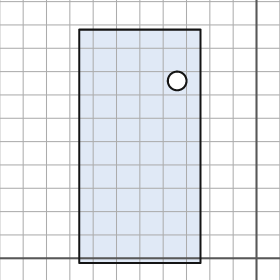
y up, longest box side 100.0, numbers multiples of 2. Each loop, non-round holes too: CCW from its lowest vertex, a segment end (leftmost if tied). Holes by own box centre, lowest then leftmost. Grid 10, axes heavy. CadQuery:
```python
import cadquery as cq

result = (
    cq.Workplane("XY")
    .moveTo(-76.0, -2.0)
    .lineTo(-24.0, -2.0)
    .lineTo(-24.0, 98.0)
    .lineTo(-76.0, 98.0)
    .close()
    .moveTo(-34.0, 76.0)
    .circle(4.0)
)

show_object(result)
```